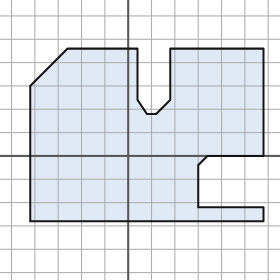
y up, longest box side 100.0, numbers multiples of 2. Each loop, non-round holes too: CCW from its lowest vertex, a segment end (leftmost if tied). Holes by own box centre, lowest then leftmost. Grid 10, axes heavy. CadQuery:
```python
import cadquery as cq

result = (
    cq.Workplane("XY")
    .moveTo(-42.0, -28.0)
    .lineTo(58.0, -28.0)
    .lineTo(58.0, -22.0)
    .lineTo(30.0, -22.0)
    .lineTo(30.0, -4.0)
    .lineTo(34.0, 0.0)
    .lineTo(58.0, 0.0)
    .lineTo(58.0, 46.0)
    .lineTo(18.0, 46.0)
    .lineTo(18.0, 24.0)
    .lineTo(12.0, 18.0)
    .lineTo(8.0, 18.0)
    .lineTo(4.0, 24.0)
    .lineTo(4.0, 46.0)
    .lineTo(-26.0, 46.0)
    .lineTo(-42.0, 30.0)
    .close()
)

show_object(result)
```